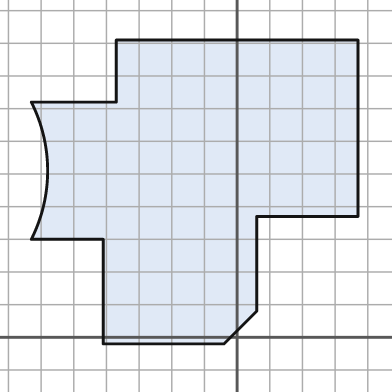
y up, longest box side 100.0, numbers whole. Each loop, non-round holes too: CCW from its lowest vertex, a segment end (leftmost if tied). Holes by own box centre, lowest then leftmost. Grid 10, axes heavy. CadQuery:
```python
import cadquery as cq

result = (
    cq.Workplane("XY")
    .moveTo(-41.0, -2.0)
    .lineTo(-4.0, -2.0)
    .lineTo(6.0, 8.0)
    .lineTo(6.0, 37.0)
    .lineTo(37.0, 37.0)
    .lineTo(37.0, 91.0)
    .lineTo(-37.0, 91.0)
    .lineTo(-37.0, 72.0)
    .lineTo(-63.0, 72.0)
    .threePointArc((-58.0, 51.0), (-63.0, 30.0))
    .lineTo(-41.0, 30.0)
    .close()
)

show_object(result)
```